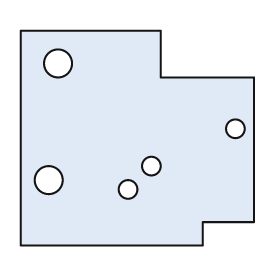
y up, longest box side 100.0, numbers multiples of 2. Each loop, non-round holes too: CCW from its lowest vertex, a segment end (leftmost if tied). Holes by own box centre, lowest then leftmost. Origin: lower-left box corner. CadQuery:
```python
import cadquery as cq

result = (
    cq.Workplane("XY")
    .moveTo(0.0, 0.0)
    .lineTo(78.0, 0.0)
    .lineTo(78.0, 10.0)
    .lineTo(100.0, 10.0)
    .lineTo(100.0, 72.0)
    .lineTo(60.0, 72.0)
    .lineTo(60.0, 92.0)
    .lineTo(0.0, 92.0)
    .close()
    .moveTo(46.0, 24.0)
    .circle(4.0)
    .moveTo(12.0, 28.0)
    .circle(6.0)
    .moveTo(56.0, 34.0)
    .circle(4.0)
    .moveTo(92.0, 50.0)
    .circle(4.0)
    .moveTo(16.0, 78.0)
    .circle(6.0)
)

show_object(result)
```